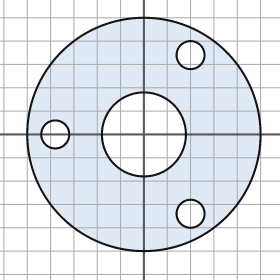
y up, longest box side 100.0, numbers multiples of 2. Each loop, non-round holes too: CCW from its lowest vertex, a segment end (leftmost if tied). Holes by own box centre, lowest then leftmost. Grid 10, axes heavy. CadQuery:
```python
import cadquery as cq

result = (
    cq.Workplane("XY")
    .moveTo(0.0, 0.0)
    .circle(50.0)
    .moveTo(20.0, -34.0)
    .circle(6.0)
    .moveTo(-38.0, 0.0)
    .circle(6.0)
    .moveTo(0.0, 0.0)
    .circle(18.0)
    .moveTo(20.0, 34.0)
    .circle(6.0)
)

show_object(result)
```